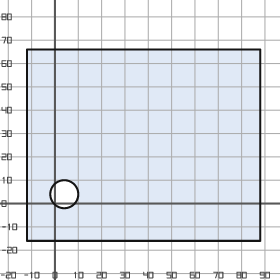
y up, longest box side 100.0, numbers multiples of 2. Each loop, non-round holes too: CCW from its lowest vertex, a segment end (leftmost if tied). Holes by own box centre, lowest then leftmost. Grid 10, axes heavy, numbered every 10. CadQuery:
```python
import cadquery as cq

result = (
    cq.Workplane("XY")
    .moveTo(-12.0, -16.0)
    .lineTo(88.0, -16.0)
    .lineTo(88.0, 66.0)
    .lineTo(-12.0, 66.0)
    .close()
    .moveTo(4.0, 4.0)
    .circle(6.0)
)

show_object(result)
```